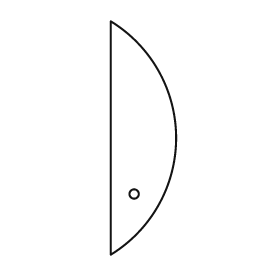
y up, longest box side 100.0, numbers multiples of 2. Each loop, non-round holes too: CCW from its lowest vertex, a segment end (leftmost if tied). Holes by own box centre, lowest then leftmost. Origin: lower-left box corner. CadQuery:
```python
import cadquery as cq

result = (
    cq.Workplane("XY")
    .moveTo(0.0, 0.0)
    .threePointArc((28.0, 50.0), (0.0, 100.0))
    .close()
    .moveTo(10.0, 26.0)
    .circle(2.0)
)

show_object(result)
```